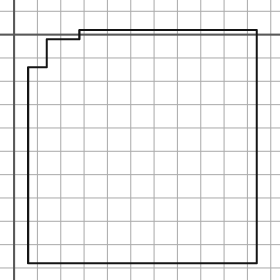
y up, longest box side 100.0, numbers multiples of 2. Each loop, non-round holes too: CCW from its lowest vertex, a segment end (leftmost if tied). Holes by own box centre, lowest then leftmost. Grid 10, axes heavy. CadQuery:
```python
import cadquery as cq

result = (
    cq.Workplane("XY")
    .moveTo(6.0, -98.0)
    .lineTo(104.0, -98.0)
    .lineTo(104.0, 2.0)
    .lineTo(28.0, 2.0)
    .lineTo(28.0, -2.0)
    .lineTo(14.0, -2.0)
    .lineTo(14.0, -14.0)
    .lineTo(6.0, -14.0)
    .close()
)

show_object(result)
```